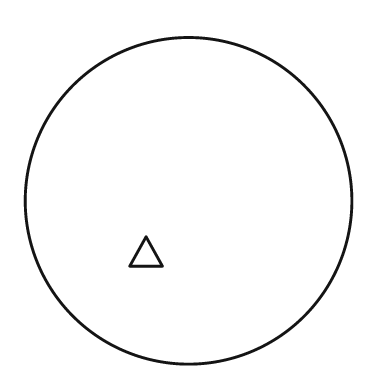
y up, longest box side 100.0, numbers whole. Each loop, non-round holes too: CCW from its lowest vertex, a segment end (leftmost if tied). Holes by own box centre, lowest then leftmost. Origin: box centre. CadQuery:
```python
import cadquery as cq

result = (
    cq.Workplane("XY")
    .moveTo(0.0, 0.0)
    .circle(50.0)
    .moveTo(-18.0, -20.0)
    .lineTo(-8.0, -20.0)
    .lineTo(-13.0, -11.0)
    .close()
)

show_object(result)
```